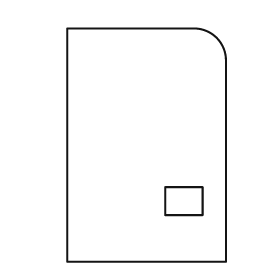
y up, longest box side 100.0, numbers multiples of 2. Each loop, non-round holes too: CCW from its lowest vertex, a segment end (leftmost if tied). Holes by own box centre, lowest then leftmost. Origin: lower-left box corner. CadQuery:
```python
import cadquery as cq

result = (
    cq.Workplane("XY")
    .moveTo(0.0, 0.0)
    .lineTo(68.0, 0.0)
    .lineTo(68.0, 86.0)
    .threePointArc((64.0, 96.0), (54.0, 100.0))
    .lineTo(0.0, 100.0)
    .close()
    .moveTo(42.0, 20.0)
    .lineTo(58.0, 20.0)
    .lineTo(58.0, 32.0)
    .lineTo(42.0, 32.0)
    .close()
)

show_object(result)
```